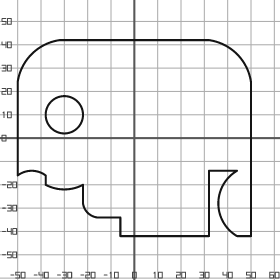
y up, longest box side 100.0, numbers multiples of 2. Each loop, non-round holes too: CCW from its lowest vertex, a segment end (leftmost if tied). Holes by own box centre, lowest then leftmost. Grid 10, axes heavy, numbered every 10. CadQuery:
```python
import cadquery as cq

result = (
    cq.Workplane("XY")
    .moveTo(-6.0, -42.0)
    .lineTo(32.0, -42.0)
    .lineTo(32.0, -14.0)
    .lineTo(44.0, -14.0)
    .threePointArc((36.0, -28.0), (44.0, -42.0))
    .lineTo(50.0, -42.0)
    .lineTo(50.0, 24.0)
    .threePointArc((44.0, 36.0), (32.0, 42.0))
    .lineTo(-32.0, 42.0)
    .threePointArc((-44.0, 36.0), (-50.0, 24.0))
    .lineTo(-50.0, -16.0)
    .threePointArc((-44.0, -14.0), (-38.0, -16.0))
    .lineTo(-38.0, -20.0)
    .threePointArc((-30.0, -22.0), (-22.0, -20.0))
    .lineTo(-22.0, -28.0)
    .threePointArc((-20.0, -32.0), (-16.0, -34.0))
    .lineTo(-6.0, -34.0)
    .close()
    .moveTo(-30.0, 10.0)
    .circle(8.0)
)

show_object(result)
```